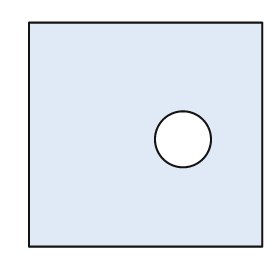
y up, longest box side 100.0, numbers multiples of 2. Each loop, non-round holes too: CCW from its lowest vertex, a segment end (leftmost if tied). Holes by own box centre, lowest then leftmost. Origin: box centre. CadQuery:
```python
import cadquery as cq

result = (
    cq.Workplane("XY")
    .moveTo(-50.0, -48.0)
    .lineTo(50.0, -48.0)
    .lineTo(50.0, 48.0)
    .lineTo(-50.0, 48.0)
    .close()
    .moveTo(16.0, -2.0)
    .circle(12.0)
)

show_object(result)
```